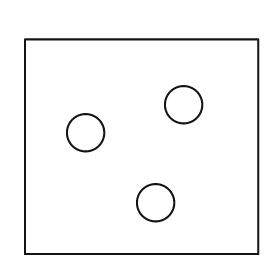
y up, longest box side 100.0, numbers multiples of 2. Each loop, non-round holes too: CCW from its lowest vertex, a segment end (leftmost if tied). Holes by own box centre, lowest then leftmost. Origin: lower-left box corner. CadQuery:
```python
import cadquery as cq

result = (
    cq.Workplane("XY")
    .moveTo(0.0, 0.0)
    .lineTo(100.0, 0.0)
    .lineTo(100.0, 92.0)
    .lineTo(0.0, 92.0)
    .close()
    .moveTo(56.0, 22.0)
    .circle(8.0)
    .moveTo(26.0, 52.0)
    .circle(8.0)
    .moveTo(68.0, 64.0)
    .circle(8.0)
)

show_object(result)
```